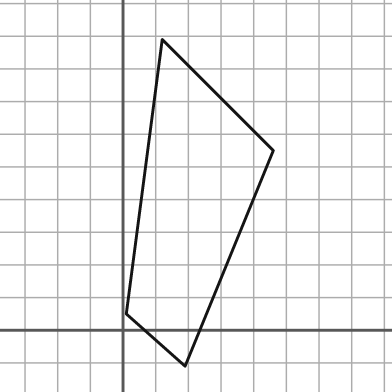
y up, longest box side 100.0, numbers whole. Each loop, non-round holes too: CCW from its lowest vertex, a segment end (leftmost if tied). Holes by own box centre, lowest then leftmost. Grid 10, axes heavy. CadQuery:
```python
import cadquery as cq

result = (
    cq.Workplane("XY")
    .moveTo(19.0, -11.0)
    .lineTo(46.0, 55.0)
    .lineTo(12.0, 89.0)
    .lineTo(1.0, 5.0)
    .close()
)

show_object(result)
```